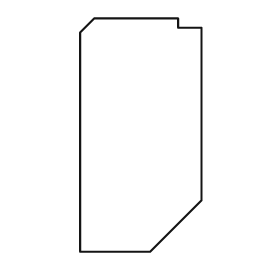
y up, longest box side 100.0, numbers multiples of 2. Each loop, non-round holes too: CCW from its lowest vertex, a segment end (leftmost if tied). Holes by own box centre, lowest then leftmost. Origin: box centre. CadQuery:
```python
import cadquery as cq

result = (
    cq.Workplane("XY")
    .moveTo(-26.0, -50.0)
    .lineTo(4.0, -50.0)
    .lineTo(26.0, -28.0)
    .lineTo(26.0, 46.0)
    .lineTo(16.0, 46.0)
    .lineTo(16.0, 50.0)
    .lineTo(-20.0, 50.0)
    .lineTo(-26.0, 44.0)
    .close()
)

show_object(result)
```